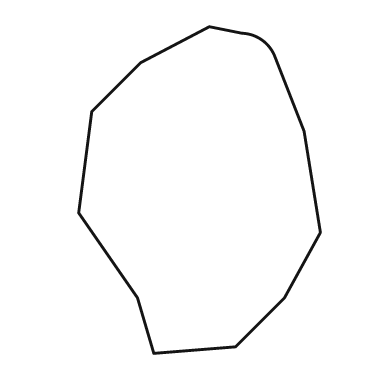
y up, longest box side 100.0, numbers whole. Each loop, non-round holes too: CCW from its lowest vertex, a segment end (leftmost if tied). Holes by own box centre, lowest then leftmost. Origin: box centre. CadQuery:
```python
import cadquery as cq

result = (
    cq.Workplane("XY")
    .moveTo(-14.0, -50.0)
    .lineTo(11.0, -48.0)
    .lineTo(26.0, -33.0)
    .lineTo(37.0, -13.0)
    .lineTo(32.0, 18.0)
    .lineTo(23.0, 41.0)
    .threePointArc((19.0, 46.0), (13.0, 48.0))
    .lineTo(3.0, 50.0)
    .lineTo(-18.0, 39.0)
    .lineTo(-33.0, 24.0)
    .lineTo(-37.0, -7.0)
    .lineTo(-19.0, -33.0)
    .close()
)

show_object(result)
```